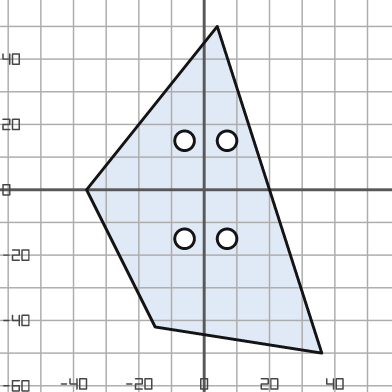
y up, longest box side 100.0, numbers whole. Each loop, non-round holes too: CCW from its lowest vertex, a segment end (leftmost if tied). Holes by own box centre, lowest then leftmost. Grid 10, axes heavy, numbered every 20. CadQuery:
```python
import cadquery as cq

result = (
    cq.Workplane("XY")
    .moveTo(36.0, -50.0)
    .lineTo(4.0, 50.0)
    .lineTo(-36.0, 0.0)
    .lineTo(-15.0, -42.0)
    .close()
    .moveTo(-6.0, -15.0)
    .circle(3.0)
    .moveTo(7.0, -15.0)
    .circle(3.0)
    .moveTo(-6.0, 15.0)
    .circle(3.0)
    .moveTo(7.0, 15.0)
    .circle(3.0)
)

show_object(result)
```